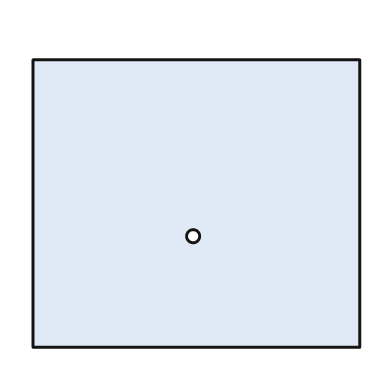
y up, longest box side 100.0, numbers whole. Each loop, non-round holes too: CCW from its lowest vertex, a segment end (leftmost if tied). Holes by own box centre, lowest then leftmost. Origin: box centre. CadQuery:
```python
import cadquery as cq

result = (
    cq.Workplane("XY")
    .moveTo(-50.0, -44.0)
    .lineTo(50.0, -44.0)
    .lineTo(50.0, 44.0)
    .lineTo(-50.0, 44.0)
    .close()
    .moveTo(-1.0, -10.0)
    .circle(2.0)
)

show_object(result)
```